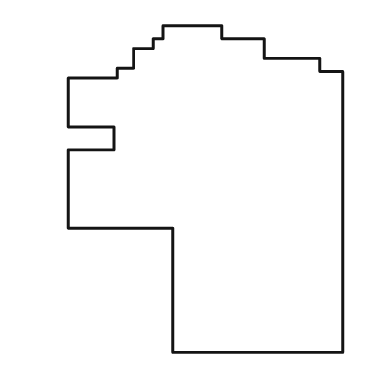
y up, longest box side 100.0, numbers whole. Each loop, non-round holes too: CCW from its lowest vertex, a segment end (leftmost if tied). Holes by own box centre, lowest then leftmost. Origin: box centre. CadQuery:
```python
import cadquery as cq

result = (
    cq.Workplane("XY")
    .moveTo(-10.0, -50.0)
    .lineTo(42.0, -50.0)
    .lineTo(42.0, 36.0)
    .lineTo(35.0, 36.0)
    .lineTo(35.0, 40.0)
    .lineTo(18.0, 40.0)
    .lineTo(18.0, 46.0)
    .lineTo(5.0, 46.0)
    .lineTo(5.0, 50.0)
    .lineTo(-13.0, 50.0)
    .lineTo(-13.0, 46.0)
    .lineTo(-16.0, 46.0)
    .lineTo(-16.0, 43.0)
    .lineTo(-22.0, 43.0)
    .lineTo(-22.0, 37.0)
    .lineTo(-27.0, 37.0)
    .lineTo(-27.0, 34.0)
    .lineTo(-42.0, 34.0)
    .lineTo(-42.0, 19.0)
    .lineTo(-28.0, 19.0)
    .lineTo(-28.0, 12.0)
    .lineTo(-42.0, 12.0)
    .lineTo(-42.0, -12.0)
    .lineTo(-10.0, -12.0)
    .close()
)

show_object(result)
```